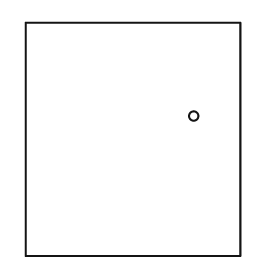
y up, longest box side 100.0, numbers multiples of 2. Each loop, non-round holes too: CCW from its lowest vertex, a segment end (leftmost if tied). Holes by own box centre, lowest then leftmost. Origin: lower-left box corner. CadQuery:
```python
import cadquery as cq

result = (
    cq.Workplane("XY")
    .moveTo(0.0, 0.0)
    .lineTo(92.0, 0.0)
    .lineTo(92.0, 100.0)
    .lineTo(0.0, 100.0)
    .close()
    .moveTo(72.0, 60.0)
    .circle(2.0)
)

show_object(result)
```